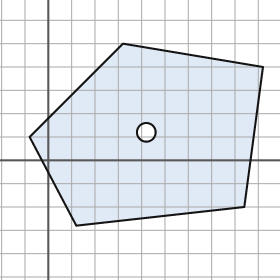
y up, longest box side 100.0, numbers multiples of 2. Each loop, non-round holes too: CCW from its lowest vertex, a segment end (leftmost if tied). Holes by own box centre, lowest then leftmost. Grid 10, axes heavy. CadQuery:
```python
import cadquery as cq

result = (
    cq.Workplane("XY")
    .moveTo(12.0, -28.0)
    .lineTo(84.0, -20.0)
    .lineTo(92.0, 40.0)
    .lineTo(32.0, 50.0)
    .lineTo(-8.0, 10.0)
    .close()
    .moveTo(42.0, 12.0)
    .circle(4.0)
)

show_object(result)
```